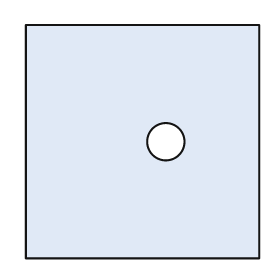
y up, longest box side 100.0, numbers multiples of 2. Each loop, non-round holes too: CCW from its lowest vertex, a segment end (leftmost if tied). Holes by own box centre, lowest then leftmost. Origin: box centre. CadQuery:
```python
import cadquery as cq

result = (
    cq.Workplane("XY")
    .moveTo(-50.0, -50.0)
    .lineTo(50.0, -50.0)
    .lineTo(50.0, 50.0)
    .lineTo(-50.0, 50.0)
    .close()
    .moveTo(10.0, 0.0)
    .circle(8.0)
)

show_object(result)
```